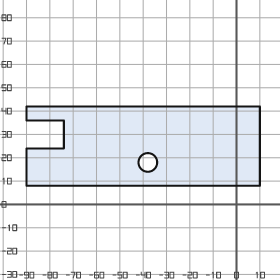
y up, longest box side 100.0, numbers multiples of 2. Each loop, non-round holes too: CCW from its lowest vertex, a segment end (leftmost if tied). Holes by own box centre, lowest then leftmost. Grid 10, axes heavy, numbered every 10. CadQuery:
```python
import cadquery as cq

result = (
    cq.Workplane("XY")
    .moveTo(-90.0, 8.0)
    .lineTo(10.0, 8.0)
    .lineTo(10.0, 42.0)
    .lineTo(-90.0, 42.0)
    .lineTo(-90.0, 36.0)
    .lineTo(-74.0, 36.0)
    .lineTo(-74.0, 24.0)
    .lineTo(-90.0, 24.0)
    .close()
    .moveTo(-38.0, 18.0)
    .circle(4.0)
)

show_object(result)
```